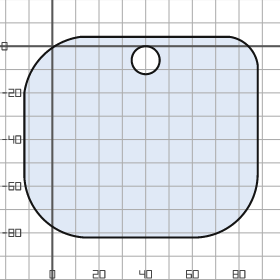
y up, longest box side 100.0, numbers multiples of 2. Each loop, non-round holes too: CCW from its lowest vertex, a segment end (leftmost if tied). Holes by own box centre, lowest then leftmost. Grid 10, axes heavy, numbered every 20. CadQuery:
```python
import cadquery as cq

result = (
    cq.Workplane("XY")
    .moveTo(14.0, -82.0)
    .lineTo(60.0, -82.0)
    .threePointArc((80.0, -74.0), (88.0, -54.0))
    .lineTo(88.0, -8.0)
    .threePointArc((84.0, 0.0), (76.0, 4.0))
    .lineTo(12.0, 4.0)
    .threePointArc((-4.0, -4.0), (-12.0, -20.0))
    .lineTo(-12.0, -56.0)
    .threePointArc((-4.0, -74.0), (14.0, -82.0))
    .close()
    .moveTo(40.0, -6.0)
    .circle(6.0)
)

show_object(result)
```